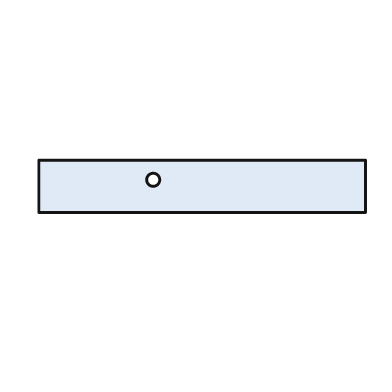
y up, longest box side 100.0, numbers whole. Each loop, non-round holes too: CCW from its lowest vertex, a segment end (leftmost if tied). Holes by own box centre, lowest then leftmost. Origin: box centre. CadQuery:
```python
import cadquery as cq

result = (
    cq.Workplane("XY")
    .moveTo(-50.0, -8.0)
    .lineTo(50.0, -8.0)
    .lineTo(50.0, 8.0)
    .lineTo(-50.0, 8.0)
    .close()
    .moveTo(-15.0, 2.0)
    .circle(2.0)
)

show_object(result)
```